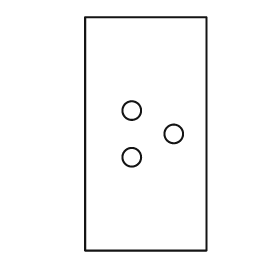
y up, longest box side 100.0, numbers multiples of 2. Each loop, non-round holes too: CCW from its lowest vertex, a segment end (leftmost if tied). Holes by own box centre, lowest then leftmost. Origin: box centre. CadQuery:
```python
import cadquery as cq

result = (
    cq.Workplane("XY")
    .moveTo(-26.0, -50.0)
    .lineTo(26.0, -50.0)
    .lineTo(26.0, 50.0)
    .lineTo(-26.0, 50.0)
    .close()
    .moveTo(-6.0, -10.0)
    .circle(4.0)
    .moveTo(12.0, 0.0)
    .circle(4.0)
    .moveTo(-6.0, 10.0)
    .circle(4.0)
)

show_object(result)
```